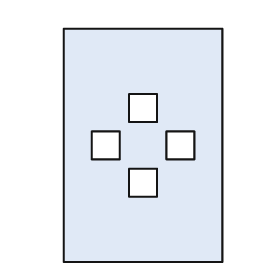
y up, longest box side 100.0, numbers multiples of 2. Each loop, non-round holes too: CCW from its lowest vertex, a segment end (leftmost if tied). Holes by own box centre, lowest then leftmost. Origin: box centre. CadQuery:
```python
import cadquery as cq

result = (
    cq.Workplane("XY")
    .moveTo(-34.0, -50.0)
    .lineTo(34.0, -50.0)
    .lineTo(34.0, 50.0)
    .lineTo(-34.0, 50.0)
    .close()
    .moveTo(-6.0, -22.0)
    .lineTo(6.0, -22.0)
    .lineTo(6.0, -10.0)
    .lineTo(-6.0, -10.0)
    .close()
    .moveTo(-22.0, -6.0)
    .lineTo(-10.0, -6.0)
    .lineTo(-10.0, 6.0)
    .lineTo(-22.0, 6.0)
    .close()
    .moveTo(10.0, -6.0)
    .lineTo(22.0, -6.0)
    .lineTo(22.0, 6.0)
    .lineTo(10.0, 6.0)
    .close()
    .moveTo(-6.0, 10.0)
    .lineTo(6.0, 10.0)
    .lineTo(6.0, 22.0)
    .lineTo(-6.0, 22.0)
    .close()
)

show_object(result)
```